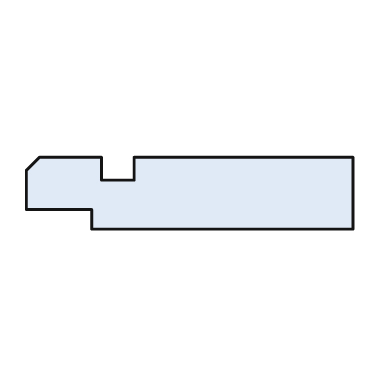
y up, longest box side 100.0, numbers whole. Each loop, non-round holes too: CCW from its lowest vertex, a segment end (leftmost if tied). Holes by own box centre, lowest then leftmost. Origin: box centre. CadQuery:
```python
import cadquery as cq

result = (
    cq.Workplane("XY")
    .moveTo(-30.0, -11.0)
    .lineTo(50.0, -11.0)
    .lineTo(50.0, 11.0)
    .lineTo(-17.0, 11.0)
    .lineTo(-17.0, 4.0)
    .lineTo(-27.0, 4.0)
    .lineTo(-27.0, 11.0)
    .lineTo(-46.0, 11.0)
    .lineTo(-50.0, 7.0)
    .lineTo(-50.0, -5.0)
    .lineTo(-30.0, -5.0)
    .close()
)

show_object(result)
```